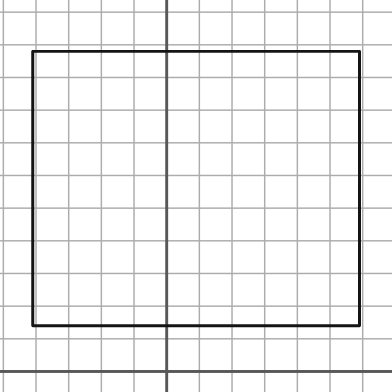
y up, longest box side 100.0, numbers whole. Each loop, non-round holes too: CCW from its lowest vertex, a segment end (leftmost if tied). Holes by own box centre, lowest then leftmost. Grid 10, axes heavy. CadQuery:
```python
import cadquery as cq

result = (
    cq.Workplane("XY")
    .moveTo(-41.0, 14.0)
    .lineTo(59.0, 14.0)
    .lineTo(59.0, 98.0)
    .lineTo(-41.0, 98.0)
    .close()
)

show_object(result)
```